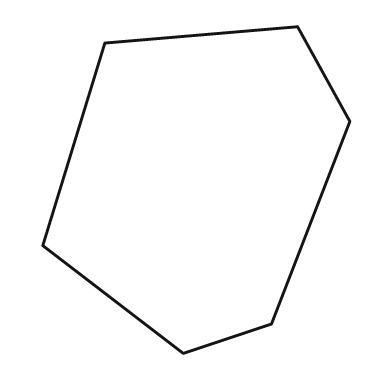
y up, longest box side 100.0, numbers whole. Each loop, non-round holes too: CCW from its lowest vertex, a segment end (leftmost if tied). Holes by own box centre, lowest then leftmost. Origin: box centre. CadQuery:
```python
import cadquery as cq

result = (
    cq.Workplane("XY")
    .moveTo(-4.0, -50.0)
    .lineTo(23.0, -41.0)
    .lineTo(47.0, 21.0)
    .lineTo(31.0, 50.0)
    .lineTo(-28.0, 45.0)
    .lineTo(-47.0, -17.0)
    .close()
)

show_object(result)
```